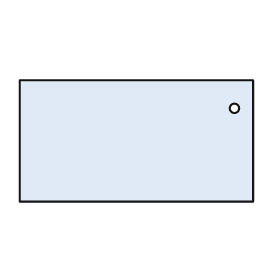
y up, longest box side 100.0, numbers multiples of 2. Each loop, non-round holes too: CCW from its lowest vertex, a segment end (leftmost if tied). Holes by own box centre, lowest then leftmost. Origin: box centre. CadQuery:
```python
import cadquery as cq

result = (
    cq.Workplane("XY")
    .moveTo(-50.0, -26.0)
    .lineTo(50.0, -26.0)
    .lineTo(50.0, 26.0)
    .lineTo(-50.0, 26.0)
    .close()
    .moveTo(42.0, 14.0)
    .circle(2.0)
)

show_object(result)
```